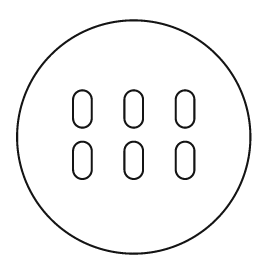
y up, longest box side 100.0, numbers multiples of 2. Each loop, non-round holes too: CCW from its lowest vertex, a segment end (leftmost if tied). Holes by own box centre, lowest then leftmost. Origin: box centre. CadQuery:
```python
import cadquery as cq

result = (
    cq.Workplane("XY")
    .moveTo(0.0, 0.0)
    .circle(50.0)
    .moveTo(-26.0, -14.0)
    .threePointArc((-22.0, -18.0), (-18.0, -14.0))
    .lineTo(-18.0, -6.0)
    .threePointArc((-22.0, -2.0), (-26.0, -6.0))
    .close()
    .moveTo(-4.0, -14.0)
    .threePointArc((0.0, -18.0), (4.0, -14.0))
    .lineTo(4.0, -6.0)
    .threePointArc((0.0, -2.0), (-4.0, -6.0))
    .close()
    .moveTo(18.0, -14.0)
    .threePointArc((22.0, -18.0), (26.0, -14.0))
    .lineTo(26.0, -6.0)
    .threePointArc((22.0, -2.0), (18.0, -6.0))
    .close()
    .moveTo(-26.0, 8.0)
    .threePointArc((-22.0, 4.0), (-18.0, 8.0))
    .lineTo(-18.0, 16.0)
    .threePointArc((-22.0, 20.0), (-26.0, 16.0))
    .close()
    .moveTo(-4.0, 8.0)
    .threePointArc((0.0, 4.0), (4.0, 8.0))
    .lineTo(4.0, 16.0)
    .threePointArc((0.0, 20.0), (-4.0, 16.0))
    .close()
    .moveTo(18.0, 8.0)
    .threePointArc((22.0, 4.0), (26.0, 8.0))
    .lineTo(26.0, 16.0)
    .threePointArc((22.0, 20.0), (18.0, 16.0))
    .close()
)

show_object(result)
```